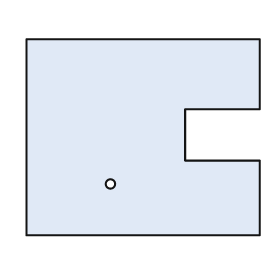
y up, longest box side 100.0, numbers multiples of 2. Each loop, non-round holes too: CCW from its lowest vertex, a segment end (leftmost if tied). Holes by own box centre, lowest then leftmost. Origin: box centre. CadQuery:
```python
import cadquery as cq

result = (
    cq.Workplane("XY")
    .moveTo(-50.0, -42.0)
    .lineTo(50.0, -42.0)
    .lineTo(50.0, -10.0)
    .lineTo(18.0, -10.0)
    .lineTo(18.0, 12.0)
    .lineTo(50.0, 12.0)
    .lineTo(50.0, 42.0)
    .lineTo(-50.0, 42.0)
    .close()
    .moveTo(-14.0, -20.0)
    .circle(2.0)
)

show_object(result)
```